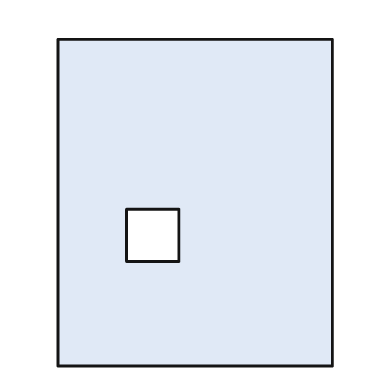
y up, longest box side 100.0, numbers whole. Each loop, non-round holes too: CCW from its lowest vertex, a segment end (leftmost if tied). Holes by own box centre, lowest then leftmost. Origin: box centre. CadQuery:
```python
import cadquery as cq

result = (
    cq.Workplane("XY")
    .moveTo(-42.0, -50.0)
    .lineTo(42.0, -50.0)
    .lineTo(42.0, 50.0)
    .lineTo(-42.0, 50.0)
    .close()
    .moveTo(-21.0, -18.0)
    .lineTo(-5.0, -18.0)
    .lineTo(-5.0, -2.0)
    .lineTo(-21.0, -2.0)
    .close()
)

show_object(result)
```